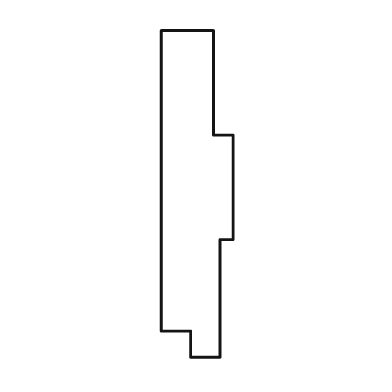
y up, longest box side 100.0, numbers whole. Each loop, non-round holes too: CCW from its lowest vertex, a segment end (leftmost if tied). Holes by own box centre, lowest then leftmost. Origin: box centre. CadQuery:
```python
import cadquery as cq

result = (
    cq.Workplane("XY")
    .moveTo(-2.0, -50.0)
    .lineTo(7.0, -50.0)
    .lineTo(7.0, -14.0)
    .lineTo(11.0, -14.0)
    .lineTo(11.0, 18.0)
    .lineTo(5.0, 18.0)
    .lineTo(5.0, 50.0)
    .lineTo(-11.0, 50.0)
    .lineTo(-11.0, -42.0)
    .lineTo(-2.0, -42.0)
    .close()
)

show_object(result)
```